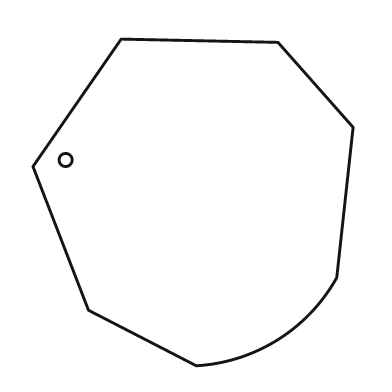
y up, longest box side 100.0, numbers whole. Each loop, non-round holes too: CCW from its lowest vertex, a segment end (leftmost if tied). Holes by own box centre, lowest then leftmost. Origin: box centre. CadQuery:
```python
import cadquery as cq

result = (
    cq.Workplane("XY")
    .moveTo(1.0, -50.0)
    .threePointArc((26.0, -42.0), (44.0, -23.0))
    .lineTo(49.0, 23.0)
    .lineTo(26.0, 49.0)
    .lineTo(-22.0, 50.0)
    .lineTo(-49.0, 11.0)
    .lineTo(-32.0, -33.0)
    .close()
    .moveTo(-39.0, 13.0)
    .circle(2.0)
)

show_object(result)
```